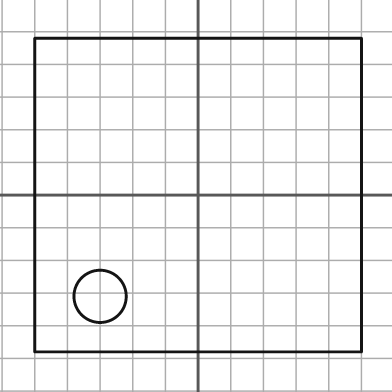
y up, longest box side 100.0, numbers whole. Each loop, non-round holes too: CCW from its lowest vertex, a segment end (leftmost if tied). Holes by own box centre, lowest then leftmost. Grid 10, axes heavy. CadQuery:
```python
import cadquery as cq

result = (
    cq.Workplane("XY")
    .moveTo(-50.0, -48.0)
    .lineTo(50.0, -48.0)
    .lineTo(50.0, 48.0)
    .lineTo(-50.0, 48.0)
    .close()
    .moveTo(-30.0, -31.0)
    .circle(8.0)
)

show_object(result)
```